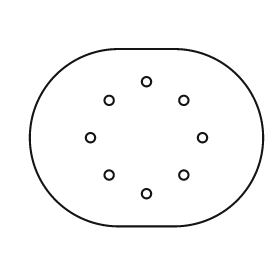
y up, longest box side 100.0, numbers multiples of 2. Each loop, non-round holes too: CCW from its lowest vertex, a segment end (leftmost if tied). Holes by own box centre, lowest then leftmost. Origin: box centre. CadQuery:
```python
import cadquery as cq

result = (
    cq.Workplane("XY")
    .moveTo(-12.0, -38.0)
    .lineTo(12.0, -38.0)
    .threePointArc((50.0, 0.0), (12.0, 38.0))
    .lineTo(-12.0, 38.0)
    .threePointArc((-50.0, 0.0), (-12.0, -38.0))
    .close()
    .moveTo(0.0, -24.0)
    .circle(2.0)
    .moveTo(-16.0, -16.0)
    .circle(2.0)
    .moveTo(16.0, -16.0)
    .circle(2.0)
    .moveTo(-24.0, 0.0)
    .circle(2.0)
    .moveTo(24.0, 0.0)
    .circle(2.0)
    .moveTo(-16.0, 16.0)
    .circle(2.0)
    .moveTo(16.0, 16.0)
    .circle(2.0)
    .moveTo(0.0, 24.0)
    .circle(2.0)
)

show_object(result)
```